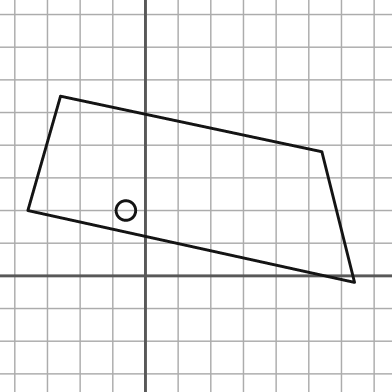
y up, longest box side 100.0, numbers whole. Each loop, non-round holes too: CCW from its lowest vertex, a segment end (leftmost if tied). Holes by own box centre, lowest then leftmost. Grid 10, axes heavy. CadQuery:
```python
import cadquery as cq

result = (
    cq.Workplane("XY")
    .moveTo(64.0, -2.0)
    .lineTo(54.0, 38.0)
    .lineTo(-26.0, 55.0)
    .lineTo(-36.0, 20.0)
    .close()
    .moveTo(-6.0, 20.0)
    .circle(3.0)
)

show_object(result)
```